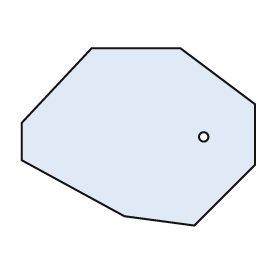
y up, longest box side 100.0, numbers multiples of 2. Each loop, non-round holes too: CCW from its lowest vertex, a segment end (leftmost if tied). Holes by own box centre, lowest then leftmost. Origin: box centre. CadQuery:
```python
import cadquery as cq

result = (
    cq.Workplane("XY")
    .moveTo(24.0, -38.0)
    .lineTo(50.0, -12.0)
    .lineTo(50.0, 14.0)
    .lineTo(18.0, 38.0)
    .lineTo(-20.0, 38.0)
    .lineTo(-50.0, 6.0)
    .lineTo(-50.0, -10.0)
    .lineTo(-6.0, -34.0)
    .close()
    .moveTo(28.0, 0.0)
    .circle(2.0)
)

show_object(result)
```